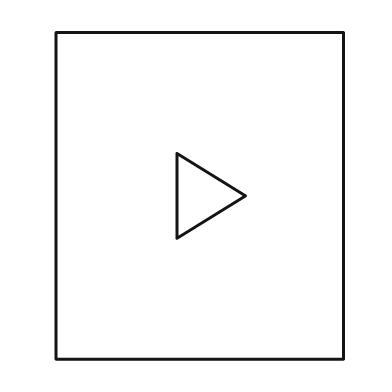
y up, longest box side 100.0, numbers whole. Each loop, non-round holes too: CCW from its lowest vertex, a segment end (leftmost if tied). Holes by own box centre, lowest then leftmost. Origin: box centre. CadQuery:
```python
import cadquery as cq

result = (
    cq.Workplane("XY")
    .moveTo(-44.0, -50.0)
    .lineTo(44.0, -50.0)
    .lineTo(44.0, 50.0)
    .lineTo(-44.0, 50.0)
    .close()
    .moveTo(-7.0, -13.0)
    .lineTo(14.0, 0.0)
    .lineTo(-7.0, 13.0)
    .close()
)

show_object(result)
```